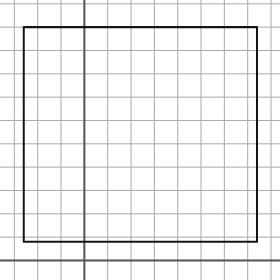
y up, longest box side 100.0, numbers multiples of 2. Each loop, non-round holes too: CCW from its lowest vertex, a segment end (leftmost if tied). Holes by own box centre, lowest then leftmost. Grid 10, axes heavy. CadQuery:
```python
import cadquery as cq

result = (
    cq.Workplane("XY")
    .moveTo(-26.0, 8.0)
    .lineTo(74.0, 8.0)
    .lineTo(74.0, 100.0)
    .lineTo(-26.0, 100.0)
    .close()
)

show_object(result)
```